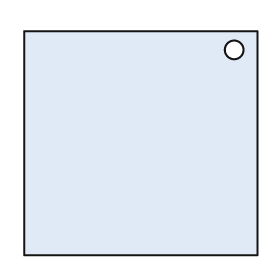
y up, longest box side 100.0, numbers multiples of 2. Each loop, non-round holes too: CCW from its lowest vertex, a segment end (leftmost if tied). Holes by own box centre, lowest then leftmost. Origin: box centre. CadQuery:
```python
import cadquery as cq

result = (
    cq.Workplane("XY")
    .moveTo(-50.0, -48.0)
    .lineTo(50.0, -48.0)
    .lineTo(50.0, 48.0)
    .lineTo(-50.0, 48.0)
    .close()
    .moveTo(40.0, 40.0)
    .circle(4.0)
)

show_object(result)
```